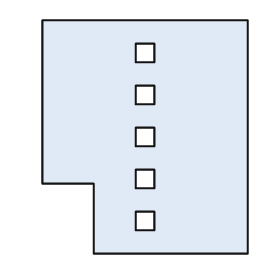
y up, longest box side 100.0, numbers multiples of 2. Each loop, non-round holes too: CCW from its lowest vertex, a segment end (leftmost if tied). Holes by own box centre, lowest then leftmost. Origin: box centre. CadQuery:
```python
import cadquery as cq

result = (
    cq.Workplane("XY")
    .moveTo(-22.0, -50.0)
    .lineTo(44.0, -50.0)
    .lineTo(44.0, 50.0)
    .lineTo(-44.0, 50.0)
    .lineTo(-44.0, -20.0)
    .lineTo(-22.0, -20.0)
    .close()
    .moveTo(-4.0, -40.0)
    .lineTo(4.0, -40.0)
    .lineTo(4.0, -32.0)
    .lineTo(-4.0, -32.0)
    .close()
    .moveTo(-4.0, -22.0)
    .lineTo(4.0, -22.0)
    .lineTo(4.0, -14.0)
    .lineTo(-4.0, -14.0)
    .close()
    .moveTo(-4.0, -4.0)
    .lineTo(4.0, -4.0)
    .lineTo(4.0, 4.0)
    .lineTo(-4.0, 4.0)
    .close()
    .moveTo(-4.0, 14.0)
    .lineTo(4.0, 14.0)
    .lineTo(4.0, 22.0)
    .lineTo(-4.0, 22.0)
    .close()
    .moveTo(-4.0, 32.0)
    .lineTo(4.0, 32.0)
    .lineTo(4.0, 40.0)
    .lineTo(-4.0, 40.0)
    .close()
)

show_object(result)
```